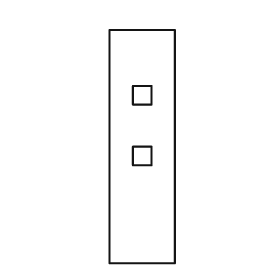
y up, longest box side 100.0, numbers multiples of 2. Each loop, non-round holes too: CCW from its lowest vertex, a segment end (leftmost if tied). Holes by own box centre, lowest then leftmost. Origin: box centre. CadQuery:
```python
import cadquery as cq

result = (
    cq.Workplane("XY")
    .moveTo(-14.0, -50.0)
    .lineTo(14.0, -50.0)
    .lineTo(14.0, 50.0)
    .lineTo(-14.0, 50.0)
    .close()
    .moveTo(-4.0, -8.0)
    .lineTo(4.0, -8.0)
    .lineTo(4.0, 0.0)
    .lineTo(-4.0, 0.0)
    .close()
    .moveTo(-4.0, 18.0)
    .lineTo(4.0, 18.0)
    .lineTo(4.0, 26.0)
    .lineTo(-4.0, 26.0)
    .close()
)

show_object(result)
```